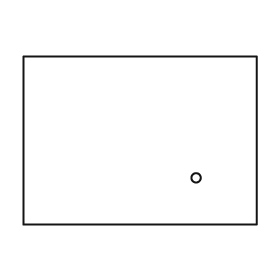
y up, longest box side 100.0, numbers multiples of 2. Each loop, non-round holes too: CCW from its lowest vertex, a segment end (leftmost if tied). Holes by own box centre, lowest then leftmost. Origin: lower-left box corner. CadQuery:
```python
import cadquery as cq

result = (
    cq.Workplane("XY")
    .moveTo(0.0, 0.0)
    .lineTo(100.0, 0.0)
    .lineTo(100.0, 72.0)
    .lineTo(0.0, 72.0)
    .close()
    .moveTo(74.0, 20.0)
    .circle(2.0)
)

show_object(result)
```